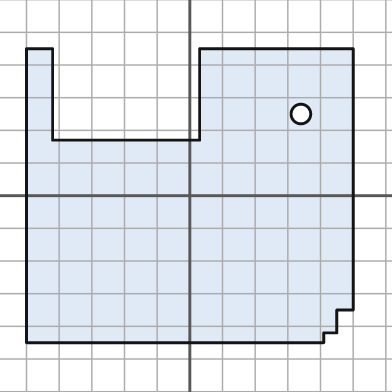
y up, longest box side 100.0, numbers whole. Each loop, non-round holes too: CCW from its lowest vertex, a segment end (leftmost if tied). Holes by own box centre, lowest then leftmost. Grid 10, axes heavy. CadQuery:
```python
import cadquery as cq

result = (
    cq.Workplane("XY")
    .moveTo(-50.0, -45.0)
    .lineTo(41.0, -45.0)
    .lineTo(41.0, -42.0)
    .lineTo(45.0, -42.0)
    .lineTo(45.0, -35.0)
    .lineTo(50.0, -35.0)
    .lineTo(50.0, 45.0)
    .lineTo(3.0, 45.0)
    .lineTo(3.0, 17.0)
    .lineTo(-42.0, 17.0)
    .lineTo(-42.0, 45.0)
    .lineTo(-50.0, 45.0)
    .close()
    .moveTo(34.0, 25.0)
    .circle(3.0)
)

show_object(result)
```